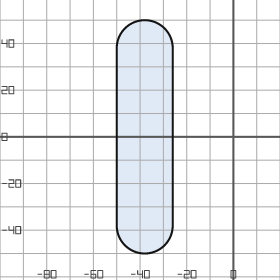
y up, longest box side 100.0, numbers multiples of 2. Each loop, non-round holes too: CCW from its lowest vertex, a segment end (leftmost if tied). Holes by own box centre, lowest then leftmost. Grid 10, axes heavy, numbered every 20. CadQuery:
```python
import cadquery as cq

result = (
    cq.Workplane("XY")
    .moveTo(-50.0, -38.0)
    .threePointArc((-38.0, -50.0), (-26.0, -38.0))
    .lineTo(-26.0, 38.0)
    .threePointArc((-38.0, 50.0), (-50.0, 38.0))
    .close()
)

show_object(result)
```